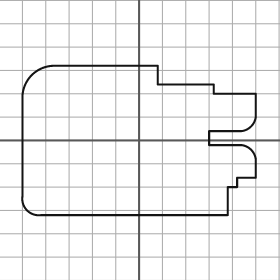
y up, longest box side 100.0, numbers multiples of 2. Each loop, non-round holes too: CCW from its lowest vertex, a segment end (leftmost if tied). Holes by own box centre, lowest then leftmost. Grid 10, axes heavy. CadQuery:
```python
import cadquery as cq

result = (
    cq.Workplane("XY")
    .moveTo(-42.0, -32.0)
    .lineTo(38.0, -32.0)
    .lineTo(38.0, -20.0)
    .lineTo(42.0, -20.0)
    .lineTo(42.0, -16.0)
    .lineTo(50.0, -16.0)
    .lineTo(50.0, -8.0)
    .threePointArc((48.0, -4.0), (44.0, -2.0))
    .lineTo(30.0, -2.0)
    .lineTo(30.0, 4.0)
    .lineTo(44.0, 4.0)
    .threePointArc((48.0, 6.0), (50.0, 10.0))
    .lineTo(50.0, 20.0)
    .lineTo(32.0, 20.0)
    .lineTo(32.0, 24.0)
    .lineTo(8.0, 24.0)
    .lineTo(8.0, 32.0)
    .lineTo(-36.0, 32.0)
    .threePointArc((-46.0, 28.0), (-50.0, 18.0))
    .lineTo(-50.0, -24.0)
    .threePointArc((-48.0, -30.0), (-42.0, -32.0))
    .close()
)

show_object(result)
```